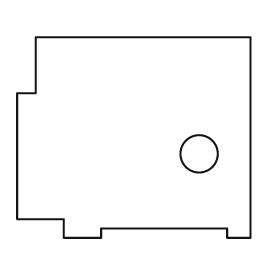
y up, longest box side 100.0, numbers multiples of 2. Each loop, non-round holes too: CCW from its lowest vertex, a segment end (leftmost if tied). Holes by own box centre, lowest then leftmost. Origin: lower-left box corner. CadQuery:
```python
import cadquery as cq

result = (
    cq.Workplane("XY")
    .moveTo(20.0, 0.0)
    .lineTo(36.0, 0.0)
    .lineTo(36.0, 4.0)
    .lineTo(90.0, 4.0)
    .lineTo(90.0, 0.0)
    .lineTo(100.0, 0.0)
    .lineTo(100.0, 86.0)
    .lineTo(8.0, 86.0)
    .lineTo(8.0, 62.0)
    .lineTo(0.0, 62.0)
    .lineTo(0.0, 8.0)
    .lineTo(20.0, 8.0)
    .close()
    .moveTo(78.0, 36.0)
    .circle(8.0)
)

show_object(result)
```